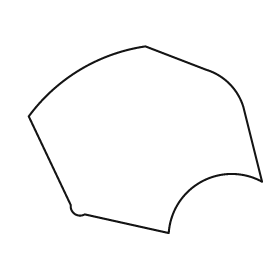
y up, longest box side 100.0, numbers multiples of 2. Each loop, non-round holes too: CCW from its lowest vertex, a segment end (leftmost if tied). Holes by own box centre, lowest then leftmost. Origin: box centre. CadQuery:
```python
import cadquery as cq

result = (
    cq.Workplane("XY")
    .moveTo(10.0, -40.0)
    .threePointArc((24.0, -18.0), (50.0, -18.0))
    .lineTo(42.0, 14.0)
    .threePointArc((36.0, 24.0), (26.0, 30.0))
    .lineTo(0.0, 40.0)
    .threePointArc((-28.0, 30.0), (-50.0, 10.0))
    .lineTo(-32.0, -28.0)
    .threePointArc((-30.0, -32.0), (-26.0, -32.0))
    .close()
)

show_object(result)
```